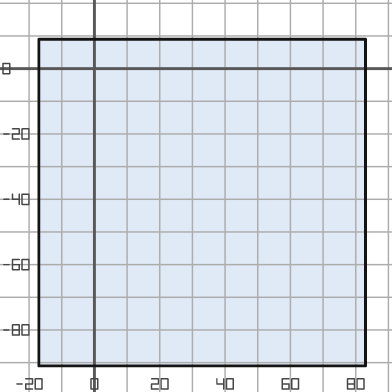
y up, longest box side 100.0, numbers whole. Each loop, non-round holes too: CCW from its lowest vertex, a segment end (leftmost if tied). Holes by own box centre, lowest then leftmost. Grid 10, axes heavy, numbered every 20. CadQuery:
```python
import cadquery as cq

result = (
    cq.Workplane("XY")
    .moveTo(-17.0, -91.0)
    .lineTo(83.0, -91.0)
    .lineTo(83.0, 9.0)
    .lineTo(-17.0, 9.0)
    .close()
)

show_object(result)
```